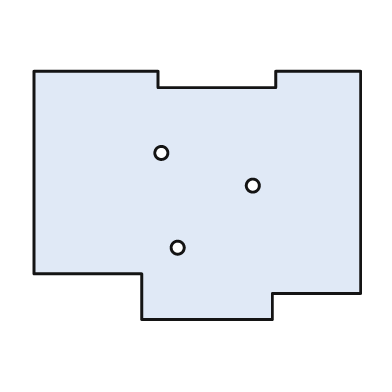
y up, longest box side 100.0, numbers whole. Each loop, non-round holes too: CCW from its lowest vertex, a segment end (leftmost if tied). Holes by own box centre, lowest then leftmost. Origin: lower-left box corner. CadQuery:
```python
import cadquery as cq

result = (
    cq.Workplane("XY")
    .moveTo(33.0, 0.0)
    .lineTo(73.0, 0.0)
    .lineTo(73.0, 8.0)
    .lineTo(100.0, 8.0)
    .lineTo(100.0, 76.0)
    .lineTo(74.0, 76.0)
    .lineTo(74.0, 71.0)
    .lineTo(38.0, 71.0)
    .lineTo(38.0, 76.0)
    .lineTo(0.0, 76.0)
    .lineTo(0.0, 14.0)
    .lineTo(33.0, 14.0)
    .close()
    .moveTo(44.0, 22.0)
    .circle(2.0)
    .moveTo(67.0, 41.0)
    .circle(2.0)
    .moveTo(39.0, 51.0)
    .circle(2.0)
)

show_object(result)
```